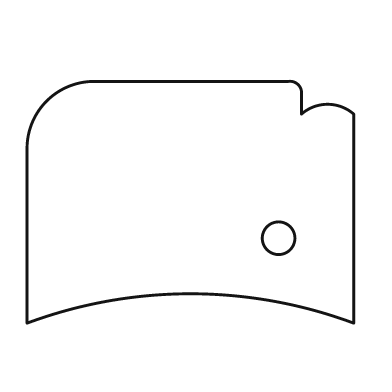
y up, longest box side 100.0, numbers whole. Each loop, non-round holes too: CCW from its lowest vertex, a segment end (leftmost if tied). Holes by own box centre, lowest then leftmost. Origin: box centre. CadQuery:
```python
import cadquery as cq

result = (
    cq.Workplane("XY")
    .moveTo(-50.0, -37.0)
    .threePointArc((0.0, -28.0), (50.0, -37.0))
    .lineTo(50.0, 27.0)
    .threePointArc((42.0, 30.0), (34.0, 27.0))
    .lineTo(34.0, 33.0)
    .threePointArc((33.0, 36.0), (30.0, 37.0))
    .lineTo(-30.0, 37.0)
    .threePointArc((-44.0, 31.0), (-50.0, 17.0))
    .close()
    .moveTo(27.0, -11.0)
    .circle(5.0)
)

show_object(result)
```